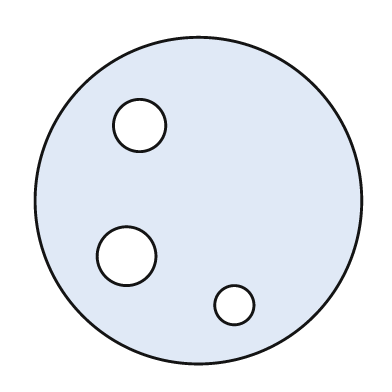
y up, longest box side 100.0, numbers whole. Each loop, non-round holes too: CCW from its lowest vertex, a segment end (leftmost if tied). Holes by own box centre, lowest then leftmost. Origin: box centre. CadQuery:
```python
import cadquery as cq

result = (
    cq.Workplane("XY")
    .moveTo(0.0, 0.0)
    .circle(50.0)
    .moveTo(11.0, -32.0)
    .circle(6.0)
    .moveTo(-22.0, -17.0)
    .circle(9.0)
    .moveTo(-18.0, 23.0)
    .circle(8.0)
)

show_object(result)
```